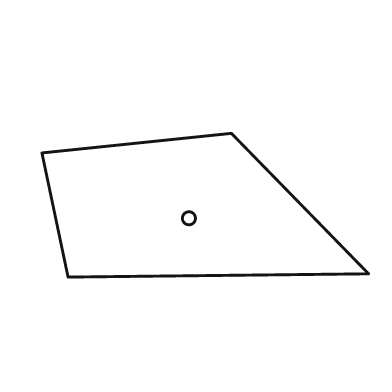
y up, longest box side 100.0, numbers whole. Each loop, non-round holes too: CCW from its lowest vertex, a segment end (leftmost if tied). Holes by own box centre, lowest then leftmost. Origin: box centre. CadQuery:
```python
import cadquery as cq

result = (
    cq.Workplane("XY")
    .moveTo(-42.0, -22.0)
    .lineTo(50.0, -21.0)
    .lineTo(8.0, 22.0)
    .lineTo(-50.0, 16.0)
    .close()
    .moveTo(-5.0, -4.0)
    .circle(2.0)
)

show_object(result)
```